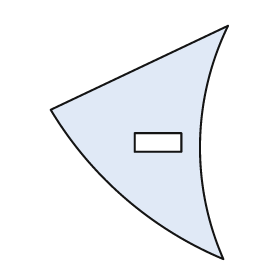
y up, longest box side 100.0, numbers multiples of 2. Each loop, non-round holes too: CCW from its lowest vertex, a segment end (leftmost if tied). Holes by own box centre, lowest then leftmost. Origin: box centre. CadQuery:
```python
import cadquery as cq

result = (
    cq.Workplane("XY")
    .moveTo(36.0, -50.0)
    .threePointArc((26.0, 0.0), (38.0, 50.0))
    .lineTo(-38.0, 14.0)
    .threePointArc((-6.0, -24.0), (36.0, -50.0))
    .close()
    .moveTo(-2.0, -4.0)
    .lineTo(18.0, -4.0)
    .lineTo(18.0, 4.0)
    .lineTo(-2.0, 4.0)
    .close()
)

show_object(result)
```